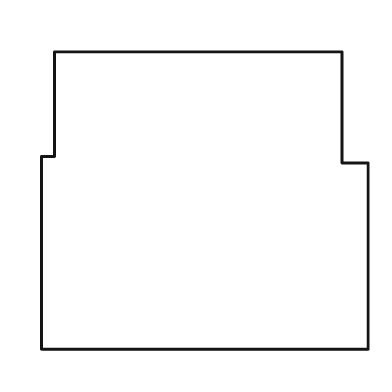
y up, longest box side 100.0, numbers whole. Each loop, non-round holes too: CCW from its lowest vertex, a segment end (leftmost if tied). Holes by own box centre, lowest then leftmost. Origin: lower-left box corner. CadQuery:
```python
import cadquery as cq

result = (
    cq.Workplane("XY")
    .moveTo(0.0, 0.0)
    .lineTo(100.0, 0.0)
    .lineTo(100.0, 57.0)
    .lineTo(92.0, 57.0)
    .lineTo(92.0, 91.0)
    .lineTo(4.0, 91.0)
    .lineTo(4.0, 59.0)
    .lineTo(0.0, 59.0)
    .close()
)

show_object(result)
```